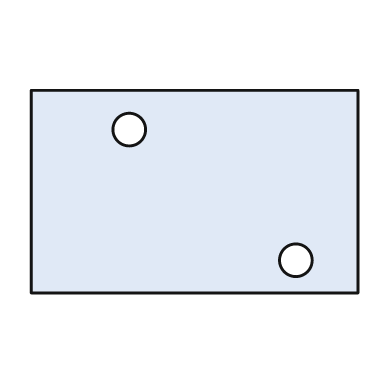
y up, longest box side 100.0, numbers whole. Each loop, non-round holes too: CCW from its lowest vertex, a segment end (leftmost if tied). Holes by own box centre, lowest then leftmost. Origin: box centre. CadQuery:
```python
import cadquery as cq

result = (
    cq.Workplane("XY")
    .moveTo(-50.0, -31.0)
    .lineTo(50.0, -31.0)
    .lineTo(50.0, 31.0)
    .lineTo(-50.0, 31.0)
    .close()
    .moveTo(31.0, -21.0)
    .circle(5.0)
    .moveTo(-20.0, 19.0)
    .circle(5.0)
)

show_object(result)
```